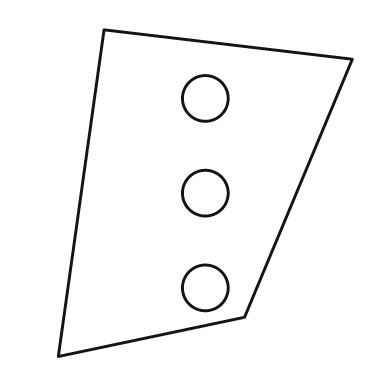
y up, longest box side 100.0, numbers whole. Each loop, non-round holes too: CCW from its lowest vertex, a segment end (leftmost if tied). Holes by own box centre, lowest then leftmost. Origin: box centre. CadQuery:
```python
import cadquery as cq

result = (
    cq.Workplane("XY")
    .moveTo(-45.0, -50.0)
    .lineTo(12.0, -38.0)
    .lineTo(45.0, 41.0)
    .lineTo(-31.0, 50.0)
    .close()
    .moveTo(0.0, -29.0)
    .circle(7.0)
    .moveTo(0.0, 0.0)
    .circle(7.0)
    .moveTo(0.0, 29.0)
    .circle(7.0)
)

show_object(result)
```